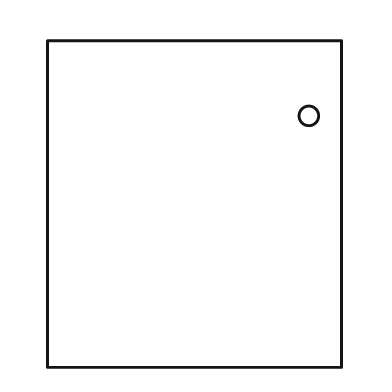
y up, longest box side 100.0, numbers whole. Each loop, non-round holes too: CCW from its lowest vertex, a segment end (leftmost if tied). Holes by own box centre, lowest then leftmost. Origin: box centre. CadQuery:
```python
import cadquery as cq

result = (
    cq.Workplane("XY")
    .moveTo(-45.0, -50.0)
    .lineTo(45.0, -50.0)
    .lineTo(45.0, 50.0)
    .lineTo(-45.0, 50.0)
    .close()
    .moveTo(35.0, 27.0)
    .circle(3.0)
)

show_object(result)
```